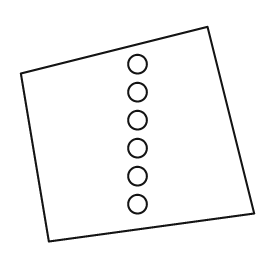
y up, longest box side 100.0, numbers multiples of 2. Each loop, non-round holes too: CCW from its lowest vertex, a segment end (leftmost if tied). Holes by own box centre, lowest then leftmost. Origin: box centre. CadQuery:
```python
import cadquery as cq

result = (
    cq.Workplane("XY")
    .moveTo(-38.0, -46.0)
    .lineTo(50.0, -34.0)
    .lineTo(30.0, 46.0)
    .lineTo(-50.0, 26.0)
    .close()
    .moveTo(0.0, -30.0)
    .circle(4.0)
    .moveTo(0.0, -18.0)
    .circle(4.0)
    .moveTo(0.0, -6.0)
    .circle(4.0)
    .moveTo(0.0, 6.0)
    .circle(4.0)
    .moveTo(0.0, 18.0)
    .circle(4.0)
    .moveTo(0.0, 30.0)
    .circle(4.0)
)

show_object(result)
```